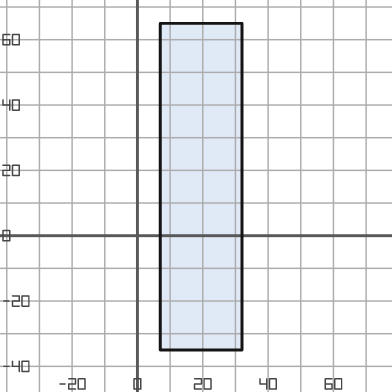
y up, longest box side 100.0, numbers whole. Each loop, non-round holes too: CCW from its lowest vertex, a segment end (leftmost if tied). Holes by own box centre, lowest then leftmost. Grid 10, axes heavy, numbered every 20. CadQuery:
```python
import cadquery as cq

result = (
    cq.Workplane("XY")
    .moveTo(7.0, -35.0)
    .lineTo(32.0, -35.0)
    .lineTo(32.0, 65.0)
    .lineTo(7.0, 65.0)
    .close()
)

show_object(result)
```